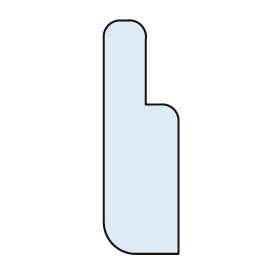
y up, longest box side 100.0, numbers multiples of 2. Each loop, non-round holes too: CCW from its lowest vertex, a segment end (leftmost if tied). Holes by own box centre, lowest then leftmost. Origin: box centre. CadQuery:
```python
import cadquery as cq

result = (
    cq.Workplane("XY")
    .moveTo(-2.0, -50.0)
    .lineTo(16.0, -50.0)
    .lineTo(16.0, 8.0)
    .threePointArc((14.0, 12.0), (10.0, 14.0))
    .lineTo(2.0, 14.0)
    .lineTo(2.0, 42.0)
    .threePointArc((0.0, 48.0), (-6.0, 50.0))
    .lineTo(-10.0, 50.0)
    .threePointArc((-14.0, 48.0), (-16.0, 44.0))
    .lineTo(-16.0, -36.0)
    .threePointArc((-12.0, -46.0), (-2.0, -50.0))
    .close()
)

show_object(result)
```